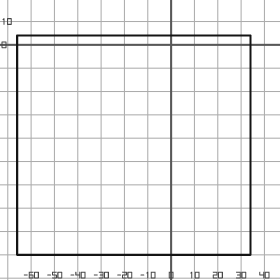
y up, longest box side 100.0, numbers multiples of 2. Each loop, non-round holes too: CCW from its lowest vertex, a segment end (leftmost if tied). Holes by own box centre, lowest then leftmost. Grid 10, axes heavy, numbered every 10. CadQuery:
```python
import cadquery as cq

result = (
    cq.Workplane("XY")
    .moveTo(-66.0, -90.0)
    .lineTo(34.0, -90.0)
    .lineTo(34.0, 4.0)
    .lineTo(-66.0, 4.0)
    .close()
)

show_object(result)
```